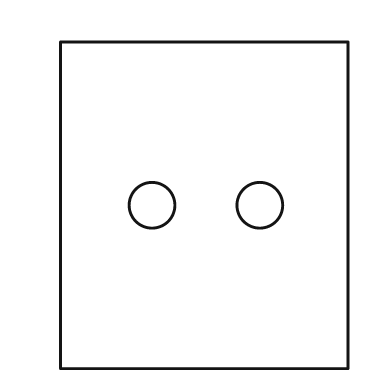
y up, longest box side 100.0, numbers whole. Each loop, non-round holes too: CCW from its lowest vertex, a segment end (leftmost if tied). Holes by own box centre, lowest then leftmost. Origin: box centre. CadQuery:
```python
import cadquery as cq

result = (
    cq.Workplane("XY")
    .moveTo(-44.0, -50.0)
    .lineTo(44.0, -50.0)
    .lineTo(44.0, 50.0)
    .lineTo(-44.0, 50.0)
    .close()
    .moveTo(-16.0, 0.0)
    .circle(7.0)
    .moveTo(17.0, 0.0)
    .circle(7.0)
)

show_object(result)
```